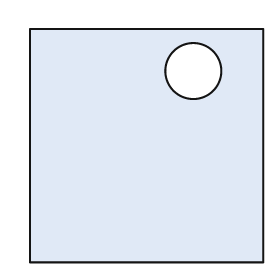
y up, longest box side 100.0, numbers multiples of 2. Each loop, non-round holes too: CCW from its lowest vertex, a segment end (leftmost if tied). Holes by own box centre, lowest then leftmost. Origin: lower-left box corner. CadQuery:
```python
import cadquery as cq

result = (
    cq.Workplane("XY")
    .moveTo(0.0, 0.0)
    .lineTo(100.0, 0.0)
    .lineTo(100.0, 100.0)
    .lineTo(0.0, 100.0)
    .close()
    .moveTo(70.0, 82.0)
    .circle(12.0)
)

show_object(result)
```